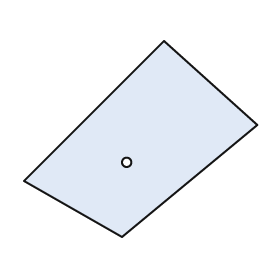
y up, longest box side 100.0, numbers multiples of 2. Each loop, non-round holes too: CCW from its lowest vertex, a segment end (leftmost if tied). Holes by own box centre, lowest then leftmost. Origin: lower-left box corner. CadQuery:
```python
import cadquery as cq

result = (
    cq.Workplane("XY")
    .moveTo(42.0, 0.0)
    .lineTo(100.0, 48.0)
    .lineTo(60.0, 84.0)
    .lineTo(0.0, 24.0)
    .close()
    .moveTo(44.0, 32.0)
    .circle(2.0)
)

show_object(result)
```